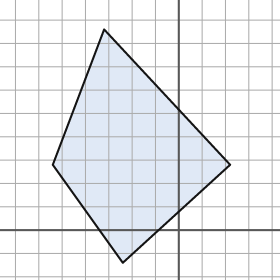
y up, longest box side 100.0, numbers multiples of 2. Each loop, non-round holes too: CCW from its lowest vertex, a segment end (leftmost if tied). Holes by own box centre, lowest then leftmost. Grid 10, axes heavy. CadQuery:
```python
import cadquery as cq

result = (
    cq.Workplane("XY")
    .moveTo(-24.0, -14.0)
    .lineTo(22.0, 28.0)
    .lineTo(-32.0, 86.0)
    .lineTo(-54.0, 28.0)
    .close()
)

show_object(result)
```